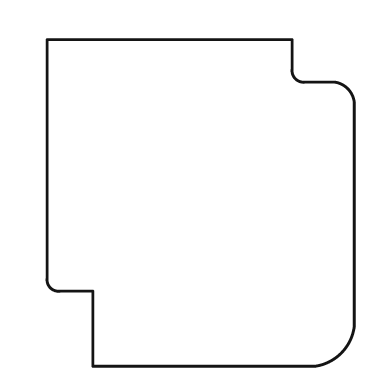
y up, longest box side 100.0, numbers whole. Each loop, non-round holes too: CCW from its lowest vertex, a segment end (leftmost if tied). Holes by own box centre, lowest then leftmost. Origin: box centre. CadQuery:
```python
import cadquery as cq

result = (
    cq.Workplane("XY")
    .moveTo(-33.0, -50.0)
    .lineTo(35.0, -50.0)
    .threePointArc((43.0, -46.0), (47.0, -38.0))
    .lineTo(47.0, 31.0)
    .threePointArc((45.0, 35.0), (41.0, 37.0))
    .lineTo(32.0, 37.0)
    .threePointArc((29.0, 38.0), (28.0, 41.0))
    .lineTo(28.0, 50.0)
    .lineTo(-47.0, 50.0)
    .lineTo(-47.0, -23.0)
    .threePointArc((-46.0, -26.0), (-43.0, -27.0))
    .lineTo(-33.0, -27.0)
    .close()
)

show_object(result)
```